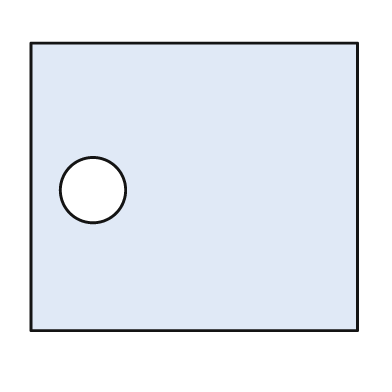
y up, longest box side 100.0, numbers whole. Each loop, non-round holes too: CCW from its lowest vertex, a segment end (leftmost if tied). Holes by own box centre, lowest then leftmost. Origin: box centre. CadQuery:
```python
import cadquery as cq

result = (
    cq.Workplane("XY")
    .moveTo(-50.0, -44.0)
    .lineTo(50.0, -44.0)
    .lineTo(50.0, 44.0)
    .lineTo(-50.0, 44.0)
    .close()
    .moveTo(-31.0, -1.0)
    .circle(10.0)
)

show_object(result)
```